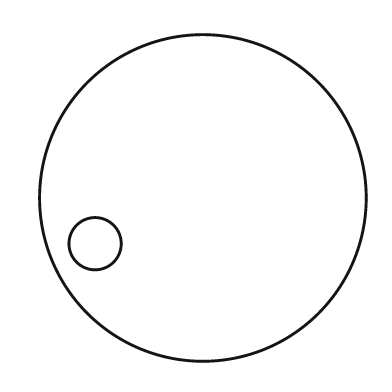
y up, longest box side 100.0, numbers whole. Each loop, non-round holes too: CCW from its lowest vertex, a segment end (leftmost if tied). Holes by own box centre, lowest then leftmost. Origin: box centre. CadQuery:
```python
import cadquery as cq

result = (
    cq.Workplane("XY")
    .moveTo(0.0, 0.0)
    .circle(50.0)
    .moveTo(-33.0, -14.0)
    .circle(8.0)
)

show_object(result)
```